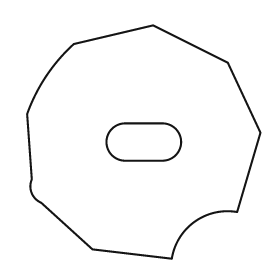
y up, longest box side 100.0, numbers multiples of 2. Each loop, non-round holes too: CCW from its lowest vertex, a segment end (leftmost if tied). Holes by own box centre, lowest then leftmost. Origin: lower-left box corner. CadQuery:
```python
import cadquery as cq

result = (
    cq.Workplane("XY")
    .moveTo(62.0, 0.0)
    .threePointArc((72.0, 16.0), (90.0, 20.0))
    .lineTo(100.0, 54.0)
    .lineTo(86.0, 84.0)
    .lineTo(54.0, 100.0)
    .lineTo(20.0, 92.0)
    .threePointArc((8.0, 78.0), (0.0, 62.0))
    .lineTo(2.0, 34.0)
    .threePointArc((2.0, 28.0), (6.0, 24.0))
    .lineTo(28.0, 4.0)
    .close()
    .moveTo(42.0, 42.0)
    .lineTo(58.0, 42.0)
    .threePointArc((66.0, 50.0), (58.0, 58.0))
    .lineTo(42.0, 58.0)
    .threePointArc((34.0, 50.0), (42.0, 42.0))
    .close()
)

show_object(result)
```